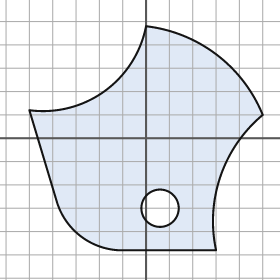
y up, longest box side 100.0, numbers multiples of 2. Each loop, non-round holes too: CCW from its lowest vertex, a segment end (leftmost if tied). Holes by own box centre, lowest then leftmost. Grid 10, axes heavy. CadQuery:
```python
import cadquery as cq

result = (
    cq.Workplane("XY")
    .moveTo(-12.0, -48.0)
    .lineTo(30.0, -48.0)
    .threePointArc((32.0, -16.0), (50.0, 10.0))
    .threePointArc((30.0, 36.0), (0.0, 48.0))
    .threePointArc((-18.0, 20.0), (-50.0, 12.0))
    .lineTo(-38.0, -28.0)
    .threePointArc((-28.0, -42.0), (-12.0, -48.0))
    .close()
    .moveTo(6.0, -30.0)
    .circle(8.0)
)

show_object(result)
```